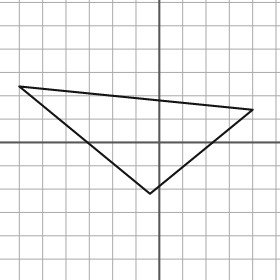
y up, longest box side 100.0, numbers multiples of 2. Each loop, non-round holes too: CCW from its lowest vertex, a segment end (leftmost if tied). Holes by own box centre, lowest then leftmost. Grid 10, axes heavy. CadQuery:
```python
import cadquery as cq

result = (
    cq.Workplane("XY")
    .moveTo(-4.0, -22.0)
    .lineTo(40.0, 14.0)
    .lineTo(-60.0, 24.0)
    .close()
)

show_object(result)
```